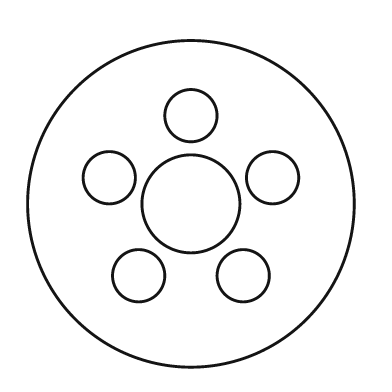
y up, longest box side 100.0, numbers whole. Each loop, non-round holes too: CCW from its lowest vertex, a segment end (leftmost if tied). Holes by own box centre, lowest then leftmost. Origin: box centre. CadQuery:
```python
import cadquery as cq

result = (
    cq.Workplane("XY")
    .moveTo(0.0, 0.0)
    .circle(50.0)
    .moveTo(-16.0, -22.0)
    .circle(8.0)
    .moveTo(16.0, -22.0)
    .circle(8.0)
    .moveTo(0.0, 0.0)
    .circle(15.0)
    .moveTo(-25.0, 8.0)
    .circle(8.0)
    .moveTo(25.0, 8.0)
    .circle(8.0)
    .moveTo(0.0, 27.0)
    .circle(8.0)
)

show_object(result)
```